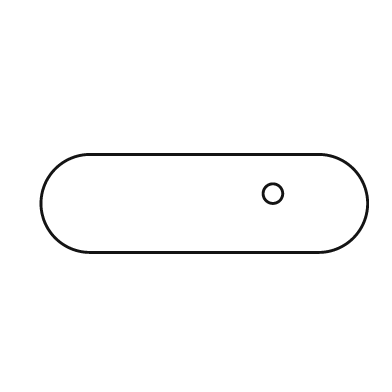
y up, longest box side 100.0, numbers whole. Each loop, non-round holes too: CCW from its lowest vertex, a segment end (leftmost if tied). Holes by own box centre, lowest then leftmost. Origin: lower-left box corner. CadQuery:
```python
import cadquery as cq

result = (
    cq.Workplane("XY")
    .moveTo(15.0, 0.0)
    .lineTo(85.0, 0.0)
    .threePointArc((100.0, 15.0), (85.0, 30.0))
    .lineTo(15.0, 30.0)
    .threePointArc((0.0, 15.0), (15.0, 0.0))
    .close()
    .moveTo(71.0, 18.0)
    .circle(3.0)
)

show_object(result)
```